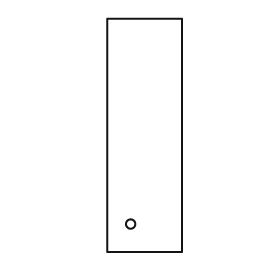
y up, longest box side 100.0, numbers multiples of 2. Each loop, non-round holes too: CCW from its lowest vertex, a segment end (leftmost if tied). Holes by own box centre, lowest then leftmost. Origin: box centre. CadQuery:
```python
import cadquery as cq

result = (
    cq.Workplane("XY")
    .moveTo(-16.0, -50.0)
    .lineTo(16.0, -50.0)
    .lineTo(16.0, 50.0)
    .lineTo(-16.0, 50.0)
    .close()
    .moveTo(-6.0, -38.0)
    .circle(2.0)
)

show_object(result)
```